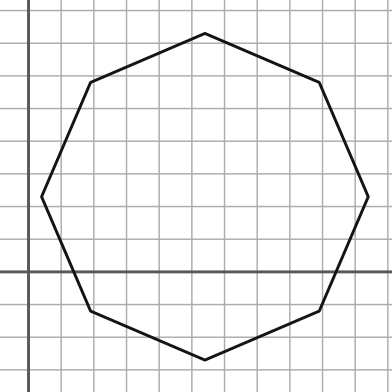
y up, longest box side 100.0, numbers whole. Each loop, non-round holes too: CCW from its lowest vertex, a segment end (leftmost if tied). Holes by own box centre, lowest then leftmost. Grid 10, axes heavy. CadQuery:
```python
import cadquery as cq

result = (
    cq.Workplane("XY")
    .moveTo(54.0, -27.0)
    .lineTo(89.0, -12.0)
    .lineTo(104.0, 23.0)
    .lineTo(89.0, 58.0)
    .lineTo(54.0, 73.0)
    .lineTo(19.0, 58.0)
    .lineTo(4.0, 23.0)
    .lineTo(19.0, -12.0)
    .close()
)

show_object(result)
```